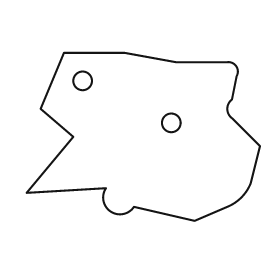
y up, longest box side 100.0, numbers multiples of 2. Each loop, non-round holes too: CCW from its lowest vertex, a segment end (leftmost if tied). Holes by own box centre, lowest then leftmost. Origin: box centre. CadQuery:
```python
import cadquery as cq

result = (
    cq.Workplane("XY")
    .moveTo(22.0, -36.0)
    .lineTo(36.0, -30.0)
    .threePointArc((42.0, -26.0), (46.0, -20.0))
    .lineTo(50.0, -4.0)
    .lineTo(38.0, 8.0)
    .threePointArc((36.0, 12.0), (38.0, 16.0))
    .lineTo(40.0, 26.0)
    .threePointArc((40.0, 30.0), (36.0, 32.0))
    .lineTo(14.0, 32.0)
    .lineTo(-8.0, 36.0)
    .lineTo(-34.0, 36.0)
    .lineTo(-44.0, 12.0)
    .lineTo(-30.0, 0.0)
    .lineTo(-50.0, -24.0)
    .lineTo(-16.0, -22.0)
    .threePointArc((-14.0, -32.0), (-4.0, -30.0))
    .close()
    .moveTo(12.0, 6.0)
    .circle(4.0)
    .moveTo(-26.0, 24.0)
    .circle(4.0)
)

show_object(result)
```